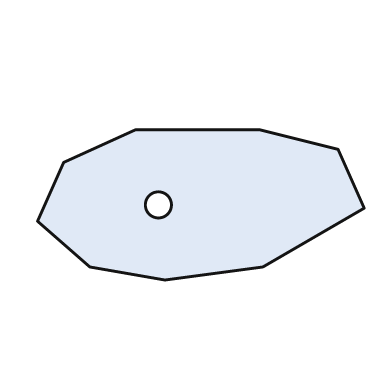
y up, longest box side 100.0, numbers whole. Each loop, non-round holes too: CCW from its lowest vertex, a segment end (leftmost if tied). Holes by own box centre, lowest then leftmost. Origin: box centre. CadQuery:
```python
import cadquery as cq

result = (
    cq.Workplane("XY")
    .moveTo(-11.0, -23.0)
    .lineTo(19.0, -19.0)
    .lineTo(50.0, -1.0)
    .lineTo(42.0, 17.0)
    .lineTo(18.0, 23.0)
    .lineTo(-20.0, 23.0)
    .lineTo(-42.0, 13.0)
    .lineTo(-50.0, -5.0)
    .lineTo(-34.0, -19.0)
    .close()
    .moveTo(-13.0, 0.0)
    .circle(4.0)
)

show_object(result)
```